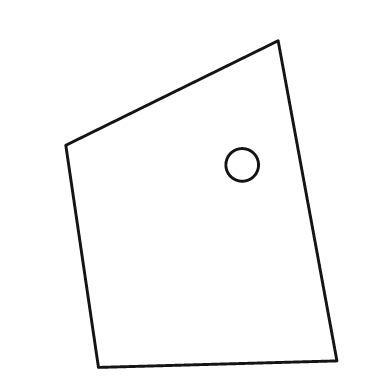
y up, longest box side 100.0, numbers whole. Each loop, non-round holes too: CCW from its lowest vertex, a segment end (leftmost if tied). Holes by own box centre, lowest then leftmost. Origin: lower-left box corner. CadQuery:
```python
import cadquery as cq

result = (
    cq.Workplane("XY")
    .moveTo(10.0, 0.0)
    .lineTo(83.0, 2.0)
    .lineTo(65.0, 100.0)
    .lineTo(0.0, 68.0)
    .close()
    .moveTo(54.0, 62.0)
    .circle(5.0)
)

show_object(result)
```